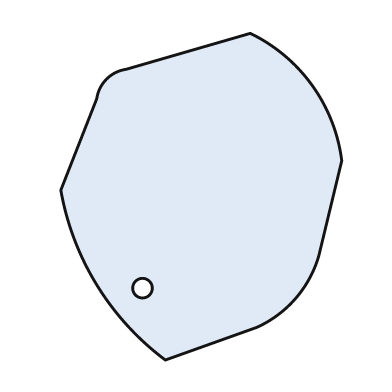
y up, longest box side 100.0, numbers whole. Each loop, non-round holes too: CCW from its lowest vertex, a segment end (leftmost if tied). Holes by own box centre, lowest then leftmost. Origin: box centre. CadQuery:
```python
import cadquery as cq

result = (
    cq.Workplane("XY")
    .moveTo(-11.0, -50.0)
    .lineTo(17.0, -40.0)
    .threePointArc((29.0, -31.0), (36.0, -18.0))
    .lineTo(43.0, 11.0)
    .threePointArc((34.0, 34.0), (15.0, 50.0))
    .lineTo(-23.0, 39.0)
    .threePointArc((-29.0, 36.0), (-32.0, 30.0))
    .lineTo(-43.0, 2.0)
    .threePointArc((-32.0, -27.0), (-11.0, -50.0))
    .close()
    .moveTo(-18.0, -28.0)
    .circle(3.0)
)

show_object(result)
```